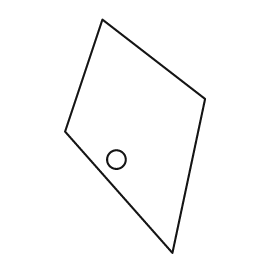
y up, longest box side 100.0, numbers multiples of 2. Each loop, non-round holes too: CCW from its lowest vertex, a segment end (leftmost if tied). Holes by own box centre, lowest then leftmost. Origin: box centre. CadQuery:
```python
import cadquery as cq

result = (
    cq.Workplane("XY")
    .moveTo(16.0, -50.0)
    .lineTo(30.0, 16.0)
    .lineTo(-14.0, 50.0)
    .lineTo(-30.0, 2.0)
    .close()
    .moveTo(-8.0, -10.0)
    .circle(4.0)
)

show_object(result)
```